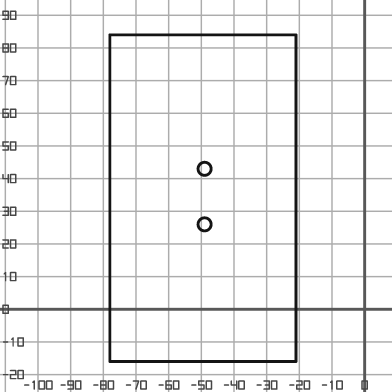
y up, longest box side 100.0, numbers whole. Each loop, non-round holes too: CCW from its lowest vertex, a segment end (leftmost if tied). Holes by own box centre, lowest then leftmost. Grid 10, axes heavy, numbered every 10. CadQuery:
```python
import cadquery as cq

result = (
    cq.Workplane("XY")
    .moveTo(-78.0, -16.0)
    .lineTo(-21.0, -16.0)
    .lineTo(-21.0, 84.0)
    .lineTo(-78.0, 84.0)
    .close()
    .moveTo(-49.0, 26.0)
    .circle(2.0)
    .moveTo(-49.0, 43.0)
    .circle(2.0)
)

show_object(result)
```